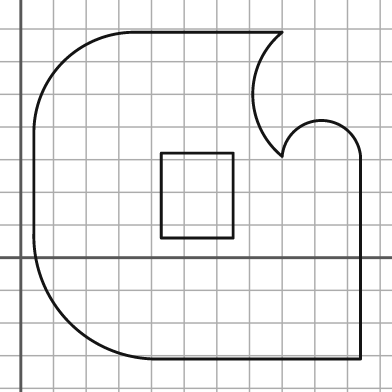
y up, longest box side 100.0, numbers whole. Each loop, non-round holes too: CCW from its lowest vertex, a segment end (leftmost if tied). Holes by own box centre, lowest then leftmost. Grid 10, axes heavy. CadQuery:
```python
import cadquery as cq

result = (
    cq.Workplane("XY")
    .moveTo(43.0, -31.0)
    .lineTo(104.0, -31.0)
    .lineTo(104.0, 31.0)
    .threePointArc((92.0, 42.0), (80.0, 31.0))
    .threePointArc((71.0, 50.0), (80.0, 69.0))
    .lineTo(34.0, 69.0)
    .threePointArc((13.0, 60.0), (4.0, 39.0))
    .lineTo(4.0, 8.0)
    .threePointArc((15.0, -20.0), (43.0, -31.0))
    .close()
    .moveTo(43.0, 6.0)
    .lineTo(65.0, 6.0)
    .lineTo(65.0, 32.0)
    .lineTo(43.0, 32.0)
    .close()
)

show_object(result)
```